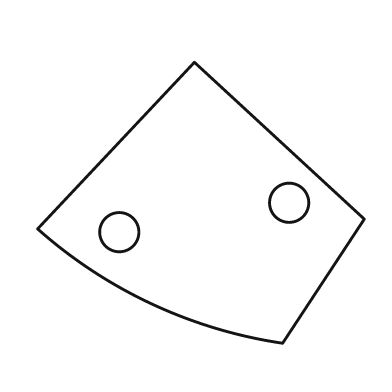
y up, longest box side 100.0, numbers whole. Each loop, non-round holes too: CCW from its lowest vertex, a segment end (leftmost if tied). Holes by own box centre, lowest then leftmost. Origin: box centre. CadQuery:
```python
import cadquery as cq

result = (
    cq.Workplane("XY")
    .moveTo(25.0, -43.0)
    .lineTo(50.0, -5.0)
    .lineTo(-2.0, 43.0)
    .lineTo(-50.0, -8.0)
    .threePointArc((-15.0, -31.0), (25.0, -43.0))
    .close()
    .moveTo(-25.0, -9.0)
    .circle(6.0)
    .moveTo(27.0, 0.0)
    .circle(6.0)
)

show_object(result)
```